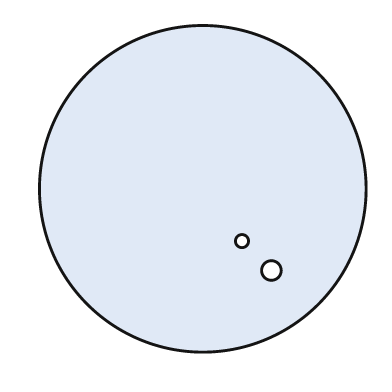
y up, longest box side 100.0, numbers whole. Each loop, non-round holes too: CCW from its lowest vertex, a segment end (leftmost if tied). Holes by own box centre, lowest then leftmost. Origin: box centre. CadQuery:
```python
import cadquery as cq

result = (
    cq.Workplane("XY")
    .moveTo(0.0, 0.0)
    .circle(50.0)
    .moveTo(21.0, -25.0)
    .circle(3.0)
    .moveTo(12.0, -16.0)
    .circle(2.0)
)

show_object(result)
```